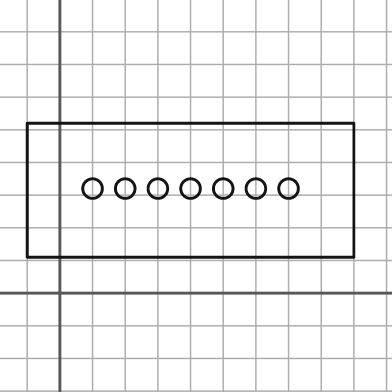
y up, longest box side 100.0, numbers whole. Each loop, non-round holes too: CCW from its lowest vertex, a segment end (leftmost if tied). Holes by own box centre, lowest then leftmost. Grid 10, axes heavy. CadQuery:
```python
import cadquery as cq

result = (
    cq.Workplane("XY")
    .moveTo(-10.0, 11.0)
    .lineTo(90.0, 11.0)
    .lineTo(90.0, 52.0)
    .lineTo(-10.0, 52.0)
    .close()
    .moveTo(10.0, 32.0)
    .circle(3.0)
    .moveTo(20.0, 32.0)
    .circle(3.0)
    .moveTo(30.0, 32.0)
    .circle(3.0)
    .moveTo(40.0, 32.0)
    .circle(3.0)
    .moveTo(50.0, 32.0)
    .circle(3.0)
    .moveTo(60.0, 32.0)
    .circle(3.0)
    .moveTo(70.0, 32.0)
    .circle(3.0)
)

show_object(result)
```